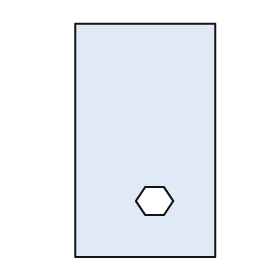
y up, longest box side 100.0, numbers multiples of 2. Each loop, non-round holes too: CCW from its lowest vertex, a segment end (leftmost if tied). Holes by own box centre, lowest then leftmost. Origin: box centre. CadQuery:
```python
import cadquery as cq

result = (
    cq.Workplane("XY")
    .moveTo(-30.0, -50.0)
    .lineTo(30.0, -50.0)
    .lineTo(30.0, 50.0)
    .lineTo(-30.0, 50.0)
    .close()
    .moveTo(0.0, -32.0)
    .lineTo(8.0, -32.0)
    .lineTo(12.0, -26.0)
    .lineTo(8.0, -20.0)
    .lineTo(0.0, -20.0)
    .lineTo(-4.0, -26.0)
    .close()
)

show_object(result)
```